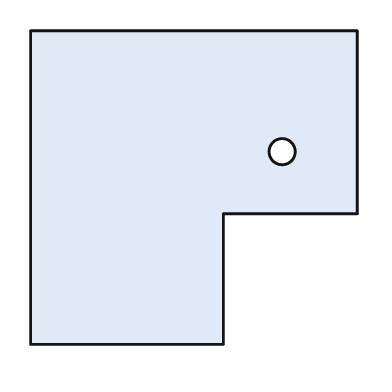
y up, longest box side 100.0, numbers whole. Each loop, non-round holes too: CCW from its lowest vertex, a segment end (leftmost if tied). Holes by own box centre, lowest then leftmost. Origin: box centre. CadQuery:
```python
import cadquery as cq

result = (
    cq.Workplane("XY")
    .moveTo(-50.0, -48.0)
    .lineTo(9.0, -48.0)
    .lineTo(9.0, -8.0)
    .lineTo(50.0, -8.0)
    .lineTo(50.0, 48.0)
    .lineTo(-50.0, 48.0)
    .close()
    .moveTo(27.0, 11.0)
    .circle(4.0)
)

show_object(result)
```